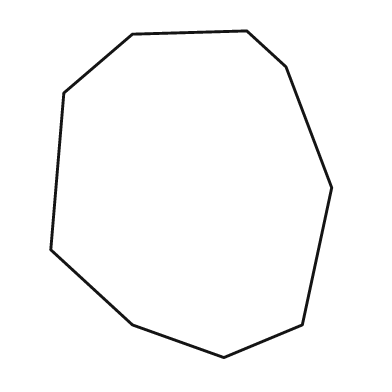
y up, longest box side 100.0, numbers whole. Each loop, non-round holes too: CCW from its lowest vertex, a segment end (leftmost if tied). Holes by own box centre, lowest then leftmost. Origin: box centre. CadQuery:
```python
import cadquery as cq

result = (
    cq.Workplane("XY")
    .moveTo(10.0, -50.0)
    .lineTo(34.0, -40.0)
    .lineTo(43.0, 2.0)
    .lineTo(29.0, 39.0)
    .lineTo(17.0, 50.0)
    .lineTo(-18.0, 49.0)
    .lineTo(-39.0, 31.0)
    .lineTo(-43.0, -17.0)
    .lineTo(-18.0, -40.0)
    .close()
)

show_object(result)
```